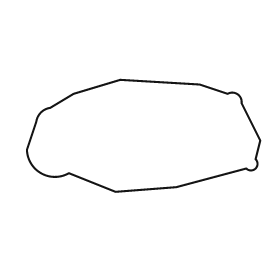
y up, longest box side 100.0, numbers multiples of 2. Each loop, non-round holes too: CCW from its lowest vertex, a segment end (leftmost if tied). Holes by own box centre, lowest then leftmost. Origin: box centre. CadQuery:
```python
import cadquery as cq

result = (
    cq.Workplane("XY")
    .moveTo(-12.0, -24.0)
    .lineTo(14.0, -22.0)
    .lineTo(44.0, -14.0)
    .threePointArc((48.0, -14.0), (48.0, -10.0))
    .lineTo(50.0, -2.0)
    .lineTo(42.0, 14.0)
    .threePointArc((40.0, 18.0), (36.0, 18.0))
    .lineTo(24.0, 22.0)
    .lineTo(-10.0, 24.0)
    .lineTo(-30.0, 18.0)
    .lineTo(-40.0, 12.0)
    .threePointArc((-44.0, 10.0), (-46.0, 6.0))
    .lineTo(-50.0, -6.0)
    .threePointArc((-44.0, -16.0), (-32.0, -16.0))
    .close()
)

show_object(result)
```